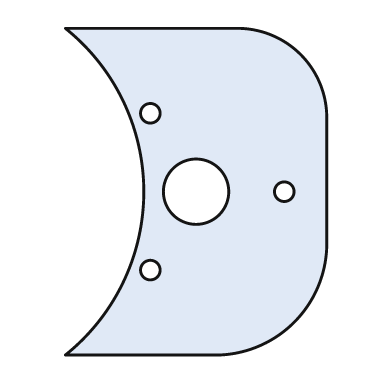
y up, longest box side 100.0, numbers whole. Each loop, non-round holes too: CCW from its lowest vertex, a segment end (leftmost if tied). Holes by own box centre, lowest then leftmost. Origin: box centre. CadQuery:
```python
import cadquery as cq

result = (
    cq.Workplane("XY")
    .moveTo(-40.0, -50.0)
    .lineTo(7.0, -50.0)
    .threePointArc((30.0, -40.0), (40.0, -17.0))
    .lineTo(40.0, 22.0)
    .threePointArc((32.0, 42.0), (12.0, 50.0))
    .lineTo(-40.0, 50.0)
    .threePointArc((-16.0, 0.0), (-40.0, -50.0))
    .close()
    .moveTo(-14.0, -24.0)
    .circle(3.0)
    .moveTo(0.0, 0.0)
    .circle(10.0)
    .moveTo(27.0, 0.0)
    .circle(3.0)
    .moveTo(-14.0, 24.0)
    .circle(3.0)
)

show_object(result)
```